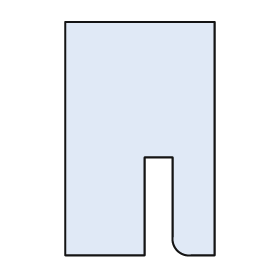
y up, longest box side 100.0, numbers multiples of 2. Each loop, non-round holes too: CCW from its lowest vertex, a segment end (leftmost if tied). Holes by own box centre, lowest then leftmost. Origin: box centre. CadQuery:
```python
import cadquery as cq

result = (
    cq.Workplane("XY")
    .moveTo(-32.0, -50.0)
    .lineTo(2.0, -50.0)
    .lineTo(2.0, -8.0)
    .lineTo(14.0, -8.0)
    .lineTo(14.0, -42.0)
    .threePointArc((16.0, -48.0), (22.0, -50.0))
    .lineTo(32.0, -50.0)
    .lineTo(32.0, 50.0)
    .lineTo(-32.0, 50.0)
    .close()
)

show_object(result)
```